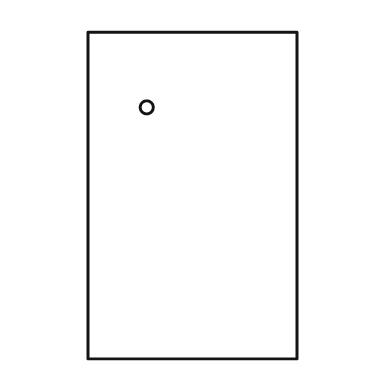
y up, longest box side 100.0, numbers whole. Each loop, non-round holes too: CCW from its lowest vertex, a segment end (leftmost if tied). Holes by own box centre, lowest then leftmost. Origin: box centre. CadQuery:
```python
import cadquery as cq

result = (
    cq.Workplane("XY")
    .moveTo(-32.0, -50.0)
    .lineTo(32.0, -50.0)
    .lineTo(32.0, 50.0)
    .lineTo(-32.0, 50.0)
    .close()
    .moveTo(-14.0, 27.0)
    .circle(2.0)
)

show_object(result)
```